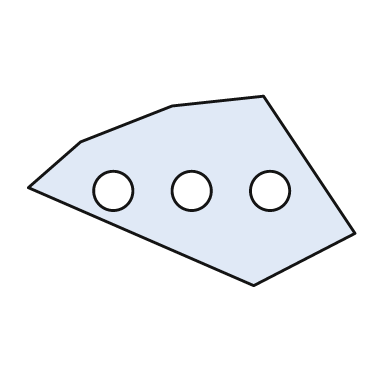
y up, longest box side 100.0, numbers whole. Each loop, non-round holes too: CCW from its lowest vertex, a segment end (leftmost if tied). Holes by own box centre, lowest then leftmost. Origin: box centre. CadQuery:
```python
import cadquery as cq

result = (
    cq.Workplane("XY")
    .moveTo(19.0, -29.0)
    .lineTo(50.0, -13.0)
    .lineTo(22.0, 29.0)
    .lineTo(-6.0, 26.0)
    .lineTo(-34.0, 15.0)
    .lineTo(-50.0, 1.0)
    .close()
    .moveTo(-24.0, 0.0)
    .circle(6.0)
    .moveTo(0.0, 0.0)
    .circle(6.0)
    .moveTo(24.0, 0.0)
    .circle(6.0)
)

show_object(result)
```